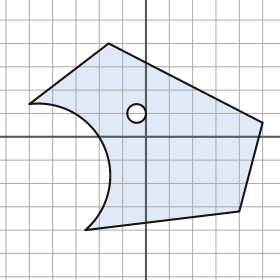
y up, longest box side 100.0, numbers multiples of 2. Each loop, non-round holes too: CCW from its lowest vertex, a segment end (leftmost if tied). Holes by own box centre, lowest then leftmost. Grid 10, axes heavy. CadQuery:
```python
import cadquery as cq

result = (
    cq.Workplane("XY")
    .moveTo(-26.0, -40.0)
    .lineTo(40.0, -32.0)
    .lineTo(50.0, 6.0)
    .lineTo(-16.0, 40.0)
    .lineTo(-50.0, 14.0)
    .threePointArc((-18.0, -4.0), (-26.0, -40.0))
    .close()
    .moveTo(-4.0, 10.0)
    .circle(4.0)
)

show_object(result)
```